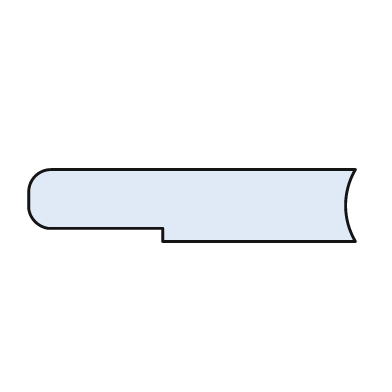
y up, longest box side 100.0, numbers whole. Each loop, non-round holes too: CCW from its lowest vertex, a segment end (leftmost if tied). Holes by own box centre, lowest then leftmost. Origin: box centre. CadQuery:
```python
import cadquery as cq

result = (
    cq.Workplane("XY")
    .moveTo(-9.0, -11.0)
    .lineTo(50.0, -11.0)
    .threePointArc((47.0, 0.0), (50.0, 11.0))
    .lineTo(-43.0, 11.0)
    .threePointArc((-48.0, 9.0), (-50.0, 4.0))
    .lineTo(-50.0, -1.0)
    .threePointArc((-48.0, -5.0), (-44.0, -7.0))
    .lineTo(-9.0, -7.0)
    .close()
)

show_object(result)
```